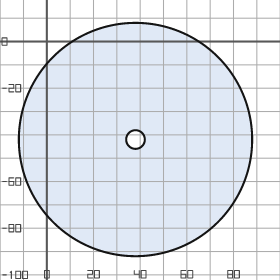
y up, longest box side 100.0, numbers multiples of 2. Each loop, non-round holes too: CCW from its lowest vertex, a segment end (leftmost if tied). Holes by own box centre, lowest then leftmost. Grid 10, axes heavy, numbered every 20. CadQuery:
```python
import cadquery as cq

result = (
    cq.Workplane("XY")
    .moveTo(38.0, -42.0)
    .circle(50.0)
    .moveTo(38.0, -42.0)
    .circle(4.0)
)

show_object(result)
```